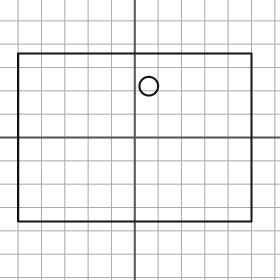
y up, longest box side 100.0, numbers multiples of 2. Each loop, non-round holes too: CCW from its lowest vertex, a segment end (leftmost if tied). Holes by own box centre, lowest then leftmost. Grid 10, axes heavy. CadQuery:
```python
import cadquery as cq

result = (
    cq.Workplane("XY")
    .moveTo(-50.0, -36.0)
    .lineTo(50.0, -36.0)
    .lineTo(50.0, 36.0)
    .lineTo(-50.0, 36.0)
    .close()
    .moveTo(6.0, 22.0)
    .circle(4.0)
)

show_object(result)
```